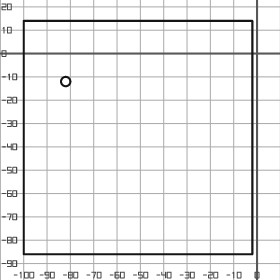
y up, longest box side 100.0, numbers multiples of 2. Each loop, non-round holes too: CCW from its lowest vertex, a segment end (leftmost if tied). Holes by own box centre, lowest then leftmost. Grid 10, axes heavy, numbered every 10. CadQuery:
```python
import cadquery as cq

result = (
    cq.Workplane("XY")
    .moveTo(-100.0, -86.0)
    .lineTo(-2.0, -86.0)
    .lineTo(-2.0, 14.0)
    .lineTo(-100.0, 14.0)
    .close()
    .moveTo(-82.0, -12.0)
    .circle(2.0)
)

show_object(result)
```